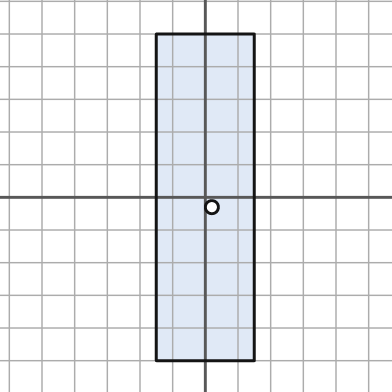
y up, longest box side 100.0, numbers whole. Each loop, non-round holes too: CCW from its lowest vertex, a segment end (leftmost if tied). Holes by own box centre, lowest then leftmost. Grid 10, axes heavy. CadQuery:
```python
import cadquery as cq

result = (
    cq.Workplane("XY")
    .moveTo(-15.0, -50.0)
    .lineTo(15.0, -50.0)
    .lineTo(15.0, 50.0)
    .lineTo(-15.0, 50.0)
    .close()
    .moveTo(2.0, -3.0)
    .circle(2.0)
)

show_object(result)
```